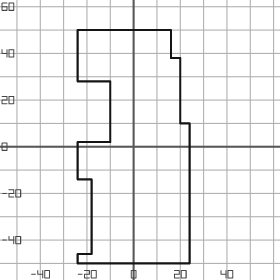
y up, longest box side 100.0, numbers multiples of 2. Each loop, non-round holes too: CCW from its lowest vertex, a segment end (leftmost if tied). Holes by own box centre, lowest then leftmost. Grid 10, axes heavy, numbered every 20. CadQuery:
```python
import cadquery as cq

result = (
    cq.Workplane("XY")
    .moveTo(-24.0, -50.0)
    .lineTo(24.0, -50.0)
    .lineTo(24.0, 10.0)
    .lineTo(20.0, 10.0)
    .lineTo(20.0, 38.0)
    .lineTo(16.0, 38.0)
    .lineTo(16.0, 50.0)
    .lineTo(-24.0, 50.0)
    .lineTo(-24.0, 28.0)
    .lineTo(-10.0, 28.0)
    .lineTo(-10.0, 2.0)
    .lineTo(-24.0, 2.0)
    .lineTo(-24.0, -14.0)
    .lineTo(-18.0, -14.0)
    .lineTo(-18.0, -46.0)
    .lineTo(-24.0, -46.0)
    .close()
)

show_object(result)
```